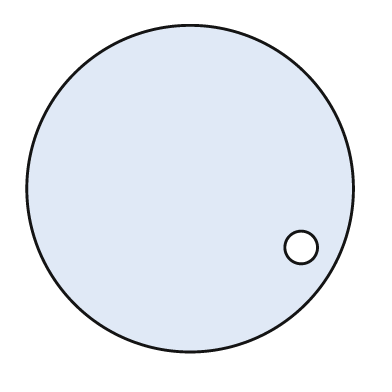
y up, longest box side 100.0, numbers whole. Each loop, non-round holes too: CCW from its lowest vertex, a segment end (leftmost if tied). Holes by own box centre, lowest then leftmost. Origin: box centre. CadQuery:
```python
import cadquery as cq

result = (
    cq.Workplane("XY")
    .moveTo(0.0, 0.0)
    .circle(50.0)
    .moveTo(34.0, -18.0)
    .circle(5.0)
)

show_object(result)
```